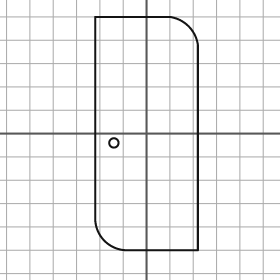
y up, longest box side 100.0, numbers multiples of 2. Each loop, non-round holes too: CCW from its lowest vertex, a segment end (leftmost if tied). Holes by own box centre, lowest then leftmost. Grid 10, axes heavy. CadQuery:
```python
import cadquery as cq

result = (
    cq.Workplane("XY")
    .moveTo(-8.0, -50.0)
    .lineTo(22.0, -50.0)
    .lineTo(22.0, 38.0)
    .threePointArc((18.0, 46.0), (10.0, 50.0))
    .lineTo(-22.0, 50.0)
    .lineTo(-22.0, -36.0)
    .threePointArc((-18.0, -46.0), (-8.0, -50.0))
    .close()
    .moveTo(-14.0, -4.0)
    .circle(2.0)
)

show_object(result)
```